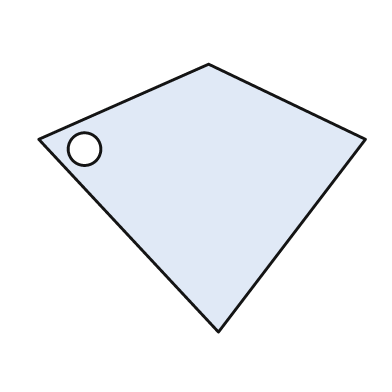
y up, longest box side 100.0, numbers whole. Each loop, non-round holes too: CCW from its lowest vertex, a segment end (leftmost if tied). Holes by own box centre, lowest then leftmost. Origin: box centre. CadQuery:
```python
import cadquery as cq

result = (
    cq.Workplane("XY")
    .moveTo(5.0, -41.0)
    .lineTo(50.0, 18.0)
    .lineTo(2.0, 41.0)
    .lineTo(-50.0, 18.0)
    .close()
    .moveTo(-36.0, 15.0)
    .circle(5.0)
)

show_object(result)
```